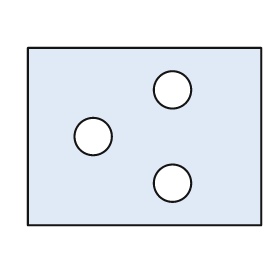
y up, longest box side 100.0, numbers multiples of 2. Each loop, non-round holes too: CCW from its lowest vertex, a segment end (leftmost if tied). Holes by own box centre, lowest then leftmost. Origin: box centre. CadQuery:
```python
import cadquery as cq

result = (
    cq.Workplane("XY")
    .moveTo(-50.0, -38.0)
    .lineTo(50.0, -38.0)
    .lineTo(50.0, 38.0)
    .lineTo(-50.0, 38.0)
    .close()
    .moveTo(12.0, -20.0)
    .circle(8.0)
    .moveTo(-22.0, 0.0)
    .circle(8.0)
    .moveTo(12.0, 20.0)
    .circle(8.0)
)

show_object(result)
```